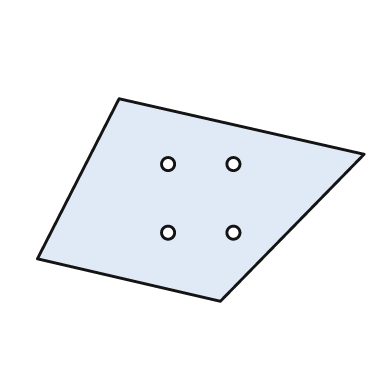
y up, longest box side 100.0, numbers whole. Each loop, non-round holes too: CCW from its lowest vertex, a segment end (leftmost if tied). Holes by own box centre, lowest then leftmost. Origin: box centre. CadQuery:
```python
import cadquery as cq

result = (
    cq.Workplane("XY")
    .moveTo(6.0, -31.0)
    .lineTo(50.0, 14.0)
    .lineTo(-25.0, 31.0)
    .lineTo(-50.0, -18.0)
    .close()
    .moveTo(-10.0, -10.0)
    .circle(2.0)
    .moveTo(10.0, -10.0)
    .circle(2.0)
    .moveTo(-10.0, 11.0)
    .circle(2.0)
    .moveTo(10.0, 11.0)
    .circle(2.0)
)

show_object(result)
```